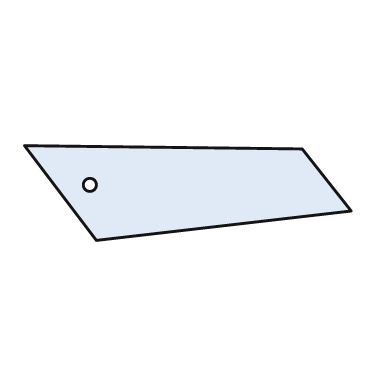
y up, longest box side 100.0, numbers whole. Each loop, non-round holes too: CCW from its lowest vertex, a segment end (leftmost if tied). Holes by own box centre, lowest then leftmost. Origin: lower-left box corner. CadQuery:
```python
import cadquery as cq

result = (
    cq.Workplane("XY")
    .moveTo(22.0, 0.0)
    .lineTo(100.0, 9.0)
    .lineTo(85.0, 28.0)
    .lineTo(0.0, 29.0)
    .close()
    .moveTo(20.0, 17.0)
    .circle(2.0)
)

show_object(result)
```